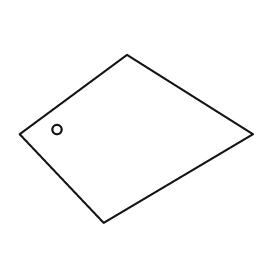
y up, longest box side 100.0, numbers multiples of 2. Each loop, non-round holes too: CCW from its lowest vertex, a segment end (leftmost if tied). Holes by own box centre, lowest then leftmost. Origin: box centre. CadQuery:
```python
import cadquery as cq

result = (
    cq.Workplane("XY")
    .moveTo(-14.0, -36.0)
    .lineTo(50.0, 2.0)
    .lineTo(-4.0, 36.0)
    .lineTo(-50.0, 2.0)
    .close()
    .moveTo(-34.0, 4.0)
    .circle(2.0)
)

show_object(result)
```